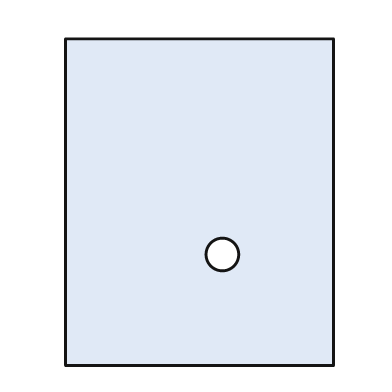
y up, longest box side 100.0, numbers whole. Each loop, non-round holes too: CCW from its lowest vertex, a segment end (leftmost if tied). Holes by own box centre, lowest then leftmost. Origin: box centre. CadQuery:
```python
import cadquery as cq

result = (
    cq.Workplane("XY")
    .moveTo(-41.0, -50.0)
    .lineTo(41.0, -50.0)
    .lineTo(41.0, 50.0)
    .lineTo(-41.0, 50.0)
    .close()
    .moveTo(7.0, -16.0)
    .circle(5.0)
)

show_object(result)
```